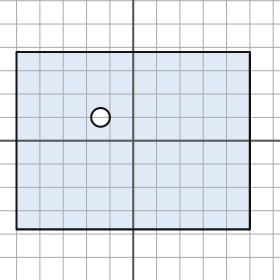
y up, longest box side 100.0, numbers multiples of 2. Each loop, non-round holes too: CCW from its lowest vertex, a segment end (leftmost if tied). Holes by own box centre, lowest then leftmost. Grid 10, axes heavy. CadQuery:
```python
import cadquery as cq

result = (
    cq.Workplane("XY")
    .moveTo(-50.0, -38.0)
    .lineTo(50.0, -38.0)
    .lineTo(50.0, 38.0)
    .lineTo(-50.0, 38.0)
    .close()
    .moveTo(-14.0, 10.0)
    .circle(4.0)
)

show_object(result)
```